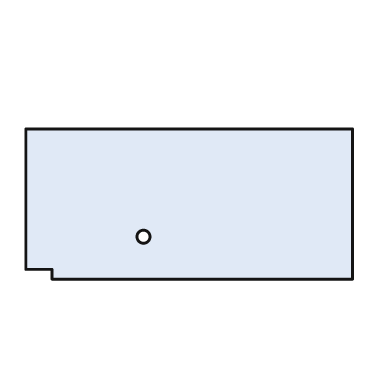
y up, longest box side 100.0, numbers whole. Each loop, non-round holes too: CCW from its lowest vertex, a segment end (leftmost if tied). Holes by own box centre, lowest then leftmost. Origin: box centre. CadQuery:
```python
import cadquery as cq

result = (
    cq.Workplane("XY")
    .moveTo(-42.0, -23.0)
    .lineTo(50.0, -23.0)
    .lineTo(50.0, 23.0)
    .lineTo(-50.0, 23.0)
    .lineTo(-50.0, -20.0)
    .lineTo(-42.0, -20.0)
    .close()
    .moveTo(-14.0, -10.0)
    .circle(2.0)
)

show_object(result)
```